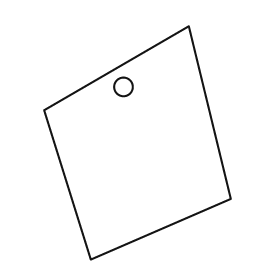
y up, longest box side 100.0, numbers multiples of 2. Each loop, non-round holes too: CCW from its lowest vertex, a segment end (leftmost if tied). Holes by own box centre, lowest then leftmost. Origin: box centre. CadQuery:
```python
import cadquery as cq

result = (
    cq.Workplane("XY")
    .moveTo(-20.0, -50.0)
    .lineTo(40.0, -24.0)
    .lineTo(22.0, 50.0)
    .lineTo(-40.0, 14.0)
    .close()
    .moveTo(-6.0, 24.0)
    .circle(4.0)
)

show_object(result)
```